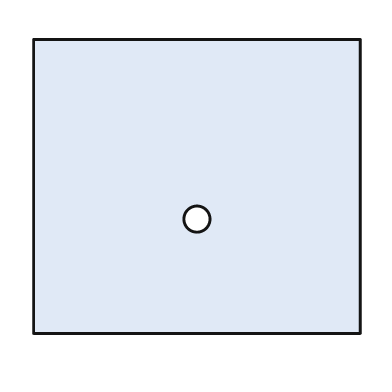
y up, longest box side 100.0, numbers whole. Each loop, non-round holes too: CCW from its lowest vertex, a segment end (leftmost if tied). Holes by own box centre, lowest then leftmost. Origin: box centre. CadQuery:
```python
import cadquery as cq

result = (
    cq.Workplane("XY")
    .moveTo(-50.0, -45.0)
    .lineTo(50.0, -45.0)
    .lineTo(50.0, 45.0)
    .lineTo(-50.0, 45.0)
    .close()
    .moveTo(0.0, -10.0)
    .circle(4.0)
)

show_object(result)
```